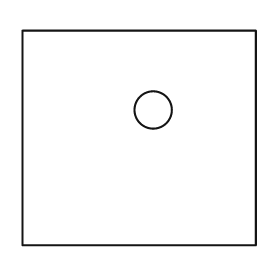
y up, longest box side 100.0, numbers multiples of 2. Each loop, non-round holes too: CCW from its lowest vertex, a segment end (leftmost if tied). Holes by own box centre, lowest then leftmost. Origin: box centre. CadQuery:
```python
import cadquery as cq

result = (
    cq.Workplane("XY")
    .moveTo(-50.0, -46.0)
    .lineTo(50.0, -46.0)
    .lineTo(50.0, 46.0)
    .lineTo(-50.0, 46.0)
    .close()
    .moveTo(6.0, 12.0)
    .circle(8.0)
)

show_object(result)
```